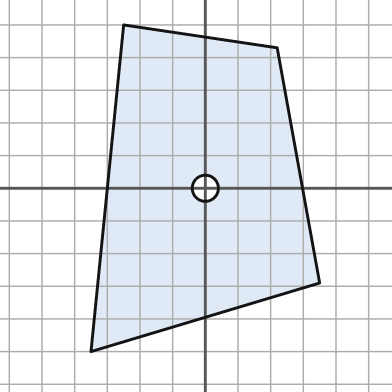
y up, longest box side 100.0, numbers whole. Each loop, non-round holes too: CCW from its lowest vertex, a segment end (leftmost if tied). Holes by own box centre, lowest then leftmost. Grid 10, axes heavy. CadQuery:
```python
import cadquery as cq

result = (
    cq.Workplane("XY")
    .moveTo(-35.0, -50.0)
    .lineTo(35.0, -29.0)
    .lineTo(22.0, 43.0)
    .lineTo(-25.0, 50.0)
    .close()
    .moveTo(0.0, 0.0)
    .circle(4.0)
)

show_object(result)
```